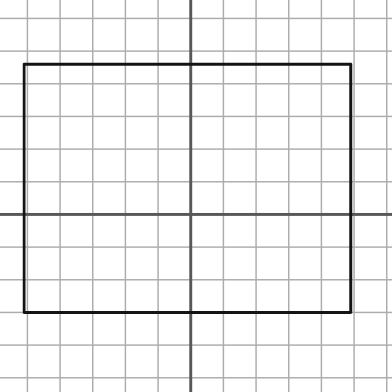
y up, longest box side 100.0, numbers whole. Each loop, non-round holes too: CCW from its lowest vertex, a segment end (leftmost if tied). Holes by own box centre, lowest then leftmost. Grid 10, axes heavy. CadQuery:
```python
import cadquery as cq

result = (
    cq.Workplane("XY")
    .moveTo(-51.0, -30.0)
    .lineTo(49.0, -30.0)
    .lineTo(49.0, 46.0)
    .lineTo(-51.0, 46.0)
    .close()
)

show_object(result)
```